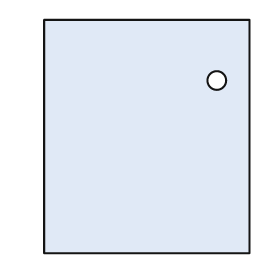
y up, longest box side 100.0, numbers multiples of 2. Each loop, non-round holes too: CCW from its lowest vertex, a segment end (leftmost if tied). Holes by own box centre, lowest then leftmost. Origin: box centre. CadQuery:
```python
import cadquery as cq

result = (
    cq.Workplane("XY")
    .moveTo(-44.0, -50.0)
    .lineTo(44.0, -50.0)
    .lineTo(44.0, 50.0)
    .lineTo(-44.0, 50.0)
    .close()
    .moveTo(30.0, 24.0)
    .circle(4.0)
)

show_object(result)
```